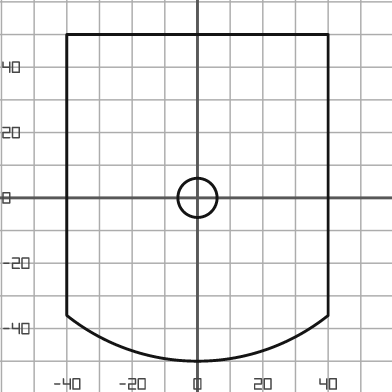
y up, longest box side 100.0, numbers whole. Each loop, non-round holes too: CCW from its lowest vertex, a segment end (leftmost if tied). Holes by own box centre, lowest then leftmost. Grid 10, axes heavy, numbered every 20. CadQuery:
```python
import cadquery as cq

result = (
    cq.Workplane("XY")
    .moveTo(-40.0, -36.0)
    .threePointArc((0.0, -50.0), (40.0, -36.0))
    .lineTo(40.0, 50.0)
    .lineTo(-40.0, 50.0)
    .close()
    .moveTo(0.0, 0.0)
    .circle(6.0)
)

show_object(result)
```